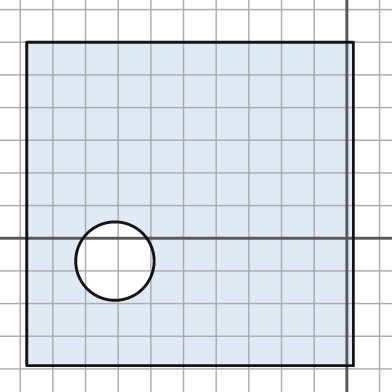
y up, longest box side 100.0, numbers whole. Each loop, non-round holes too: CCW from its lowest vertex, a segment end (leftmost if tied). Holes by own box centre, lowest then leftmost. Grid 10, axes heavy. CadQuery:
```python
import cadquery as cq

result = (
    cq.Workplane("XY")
    .moveTo(-98.0, -39.0)
    .lineTo(2.0, -39.0)
    .lineTo(2.0, 60.0)
    .lineTo(-98.0, 60.0)
    .close()
    .moveTo(-71.0, -7.0)
    .circle(12.0)
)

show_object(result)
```